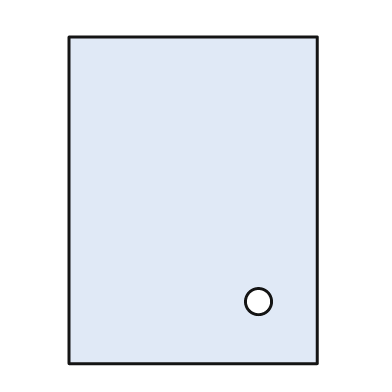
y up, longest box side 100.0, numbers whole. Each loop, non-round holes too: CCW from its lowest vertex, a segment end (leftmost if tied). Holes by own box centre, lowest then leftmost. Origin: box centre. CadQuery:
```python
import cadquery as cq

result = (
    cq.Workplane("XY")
    .moveTo(-38.0, -50.0)
    .lineTo(38.0, -50.0)
    .lineTo(38.0, 50.0)
    .lineTo(-38.0, 50.0)
    .close()
    .moveTo(20.0, -31.0)
    .circle(4.0)
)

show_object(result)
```